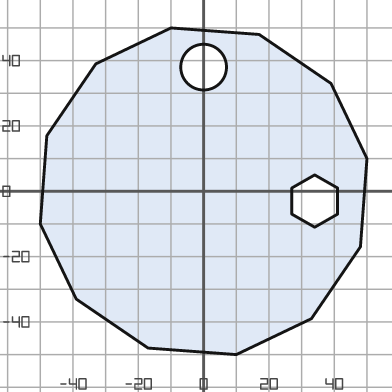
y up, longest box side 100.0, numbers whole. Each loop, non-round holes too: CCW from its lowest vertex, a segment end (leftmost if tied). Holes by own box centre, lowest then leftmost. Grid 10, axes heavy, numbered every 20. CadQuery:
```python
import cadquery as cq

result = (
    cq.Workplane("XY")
    .moveTo(10.0, -50.0)
    .lineTo(33.0, -39.0)
    .lineTo(48.0, -17.0)
    .lineTo(50.0, 10.0)
    .lineTo(39.0, 33.0)
    .lineTo(17.0, 48.0)
    .lineTo(-10.0, 50.0)
    .lineTo(-33.0, 39.0)
    .lineTo(-48.0, 17.0)
    .lineTo(-50.0, -10.0)
    .lineTo(-39.0, -33.0)
    .lineTo(-17.0, -48.0)
    .close()
    .moveTo(34.0, -11.0)
    .lineTo(41.0, -7.0)
    .lineTo(41.0, 1.0)
    .lineTo(34.0, 5.0)
    .lineTo(27.0, 1.0)
    .lineTo(27.0, -7.0)
    .close()
    .moveTo(0.0, 38.0)
    .circle(7.0)
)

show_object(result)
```